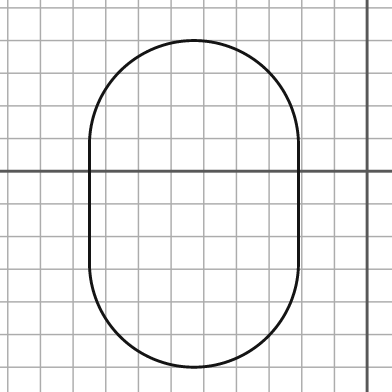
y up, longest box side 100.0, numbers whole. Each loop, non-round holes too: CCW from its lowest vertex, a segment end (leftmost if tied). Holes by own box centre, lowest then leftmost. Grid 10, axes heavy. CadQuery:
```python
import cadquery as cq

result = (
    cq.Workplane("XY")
    .moveTo(-85.0, -28.0)
    .threePointArc((-53.0, -60.0), (-21.0, -28.0))
    .lineTo(-21.0, 8.0)
    .threePointArc((-53.0, 40.0), (-85.0, 8.0))
    .close()
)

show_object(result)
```